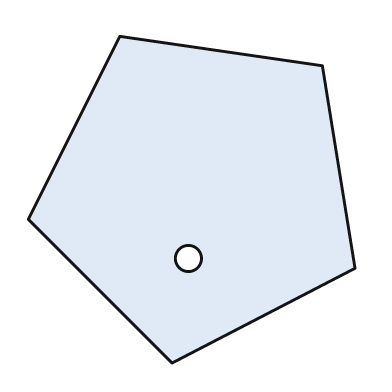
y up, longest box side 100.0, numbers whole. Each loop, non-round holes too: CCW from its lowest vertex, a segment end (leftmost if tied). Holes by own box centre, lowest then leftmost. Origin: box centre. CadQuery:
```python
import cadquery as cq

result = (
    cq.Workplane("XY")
    .moveTo(-6.0, -50.0)
    .lineTo(50.0, -21.0)
    .lineTo(40.0, 41.0)
    .lineTo(-22.0, 50.0)
    .lineTo(-50.0, -6.0)
    .close()
    .moveTo(-1.0, -18.0)
    .circle(4.0)
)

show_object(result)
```